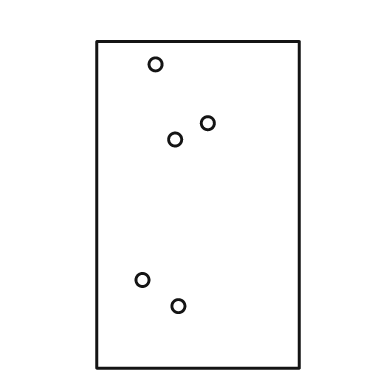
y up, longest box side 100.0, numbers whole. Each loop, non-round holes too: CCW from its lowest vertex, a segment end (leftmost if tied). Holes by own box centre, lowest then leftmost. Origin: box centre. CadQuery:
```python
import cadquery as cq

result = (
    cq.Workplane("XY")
    .moveTo(-31.0, -50.0)
    .lineTo(31.0, -50.0)
    .lineTo(31.0, 50.0)
    .lineTo(-31.0, 50.0)
    .close()
    .moveTo(-6.0, -31.0)
    .circle(2.0)
    .moveTo(-17.0, -23.0)
    .circle(2.0)
    .moveTo(-7.0, 20.0)
    .circle(2.0)
    .moveTo(3.0, 25.0)
    .circle(2.0)
    .moveTo(-13.0, 43.0)
    .circle(2.0)
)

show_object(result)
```